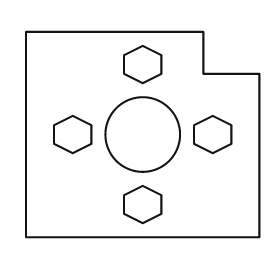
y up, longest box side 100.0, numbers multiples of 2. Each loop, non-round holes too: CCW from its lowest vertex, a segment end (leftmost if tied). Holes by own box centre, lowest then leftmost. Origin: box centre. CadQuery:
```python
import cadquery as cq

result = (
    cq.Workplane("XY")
    .moveTo(-50.0, -44.0)
    .lineTo(50.0, -44.0)
    .lineTo(50.0, 26.0)
    .lineTo(26.0, 26.0)
    .lineTo(26.0, 44.0)
    .lineTo(-50.0, 44.0)
    .close()
    .moveTo(0.0, -38.0)
    .lineTo(8.0, -34.0)
    .lineTo(8.0, -26.0)
    .lineTo(0.0, -22.0)
    .lineTo(-8.0, -26.0)
    .lineTo(-8.0, -34.0)
    .close()
    .moveTo(-30.0, -8.0)
    .lineTo(-22.0, -4.0)
    .lineTo(-22.0, 4.0)
    .lineTo(-30.0, 8.0)
    .lineTo(-38.0, 4.0)
    .lineTo(-38.0, -4.0)
    .close()
    .moveTo(0.0, 0.0)
    .circle(16.0)
    .moveTo(30.0, -8.0)
    .lineTo(38.0, -4.0)
    .lineTo(38.0, 4.0)
    .lineTo(30.0, 8.0)
    .lineTo(22.0, 4.0)
    .lineTo(22.0, -4.0)
    .close()
    .moveTo(0.0, 22.0)
    .lineTo(8.0, 26.0)
    .lineTo(8.0, 34.0)
    .lineTo(0.0, 38.0)
    .lineTo(-8.0, 34.0)
    .lineTo(-8.0, 26.0)
    .close()
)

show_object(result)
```